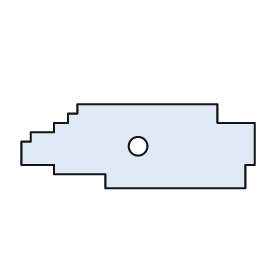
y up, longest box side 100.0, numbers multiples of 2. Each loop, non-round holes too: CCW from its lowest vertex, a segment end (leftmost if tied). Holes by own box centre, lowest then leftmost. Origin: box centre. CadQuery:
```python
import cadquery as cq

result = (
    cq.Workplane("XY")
    .moveTo(-14.0, -18.0)
    .lineTo(46.0, -18.0)
    .lineTo(46.0, -8.0)
    .lineTo(50.0, -8.0)
    .lineTo(50.0, 10.0)
    .lineTo(34.0, 10.0)
    .lineTo(34.0, 18.0)
    .lineTo(-26.0, 18.0)
    .lineTo(-26.0, 14.0)
    .lineTo(-30.0, 14.0)
    .lineTo(-30.0, 10.0)
    .lineTo(-36.0, 10.0)
    .lineTo(-36.0, 6.0)
    .lineTo(-46.0, 6.0)
    .lineTo(-46.0, 2.0)
    .lineTo(-50.0, 2.0)
    .lineTo(-50.0, -8.0)
    .lineTo(-36.0, -8.0)
    .lineTo(-36.0, -12.0)
    .lineTo(-14.0, -12.0)
    .close()
    .moveTo(0.0, 0.0)
    .circle(4.0)
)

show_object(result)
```